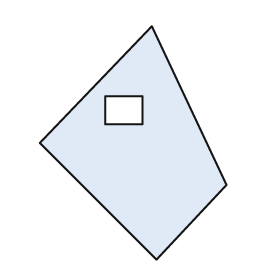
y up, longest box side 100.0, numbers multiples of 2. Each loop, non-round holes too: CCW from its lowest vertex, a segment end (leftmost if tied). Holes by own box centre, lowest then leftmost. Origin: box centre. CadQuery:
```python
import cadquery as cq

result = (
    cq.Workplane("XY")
    .moveTo(10.0, -50.0)
    .lineTo(40.0, -18.0)
    .lineTo(8.0, 50.0)
    .lineTo(-40.0, 0.0)
    .close()
    .moveTo(-12.0, 8.0)
    .lineTo(4.0, 8.0)
    .lineTo(4.0, 20.0)
    .lineTo(-12.0, 20.0)
    .close()
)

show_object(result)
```